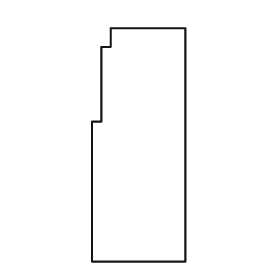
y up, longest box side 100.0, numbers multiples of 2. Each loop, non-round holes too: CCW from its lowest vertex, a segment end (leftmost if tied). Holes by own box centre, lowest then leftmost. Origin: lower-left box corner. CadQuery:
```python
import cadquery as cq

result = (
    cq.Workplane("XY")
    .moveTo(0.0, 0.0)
    .lineTo(40.0, 0.0)
    .lineTo(40.0, 100.0)
    .lineTo(8.0, 100.0)
    .lineTo(8.0, 92.0)
    .lineTo(4.0, 92.0)
    .lineTo(4.0, 60.0)
    .lineTo(0.0, 60.0)
    .close()
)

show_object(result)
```